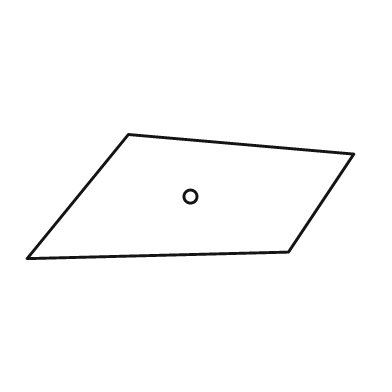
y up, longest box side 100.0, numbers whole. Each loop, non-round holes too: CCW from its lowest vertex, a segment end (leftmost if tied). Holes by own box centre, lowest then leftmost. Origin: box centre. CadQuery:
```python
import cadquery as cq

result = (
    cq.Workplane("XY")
    .moveTo(-50.0, -19.0)
    .lineTo(30.0, -17.0)
    .lineTo(50.0, 13.0)
    .lineTo(-19.0, 19.0)
    .close()
    .moveTo(0.0, 0.0)
    .circle(2.0)
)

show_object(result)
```